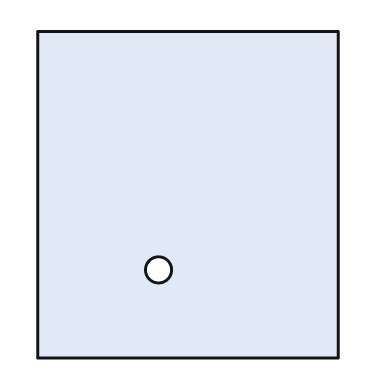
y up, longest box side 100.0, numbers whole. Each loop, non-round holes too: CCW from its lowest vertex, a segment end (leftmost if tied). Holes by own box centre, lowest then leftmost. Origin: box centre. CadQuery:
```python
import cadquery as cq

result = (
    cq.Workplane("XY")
    .moveTo(-46.0, -50.0)
    .lineTo(46.0, -50.0)
    .lineTo(46.0, 50.0)
    .lineTo(-46.0, 50.0)
    .close()
    .moveTo(-9.0, -23.0)
    .circle(4.0)
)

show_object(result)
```